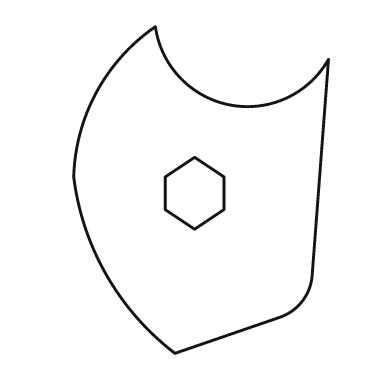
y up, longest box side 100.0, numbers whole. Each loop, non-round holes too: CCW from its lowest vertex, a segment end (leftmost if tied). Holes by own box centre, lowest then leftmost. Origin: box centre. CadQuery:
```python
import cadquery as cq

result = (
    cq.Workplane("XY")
    .moveTo(-8.0, -50.0)
    .lineTo(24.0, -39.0)
    .threePointArc((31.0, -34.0), (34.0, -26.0))
    .lineTo(39.0, 40.0)
    .threePointArc((9.0, 26.0), (-14.0, 50.0))
    .threePointArc((-32.0, 30.0), (-39.0, 4.0))
    .threePointArc((-29.0, -26.0), (-8.0, -50.0))
    .close()
    .moveTo(-2.0, -12.0)
    .lineTo(7.0, -6.0)
    .lineTo(7.0, 4.0)
    .lineTo(-2.0, 10.0)
    .lineTo(-11.0, 4.0)
    .lineTo(-11.0, -6.0)
    .close()
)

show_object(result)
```